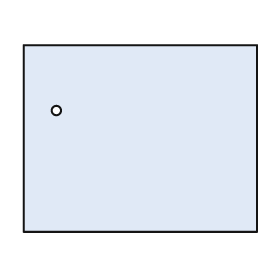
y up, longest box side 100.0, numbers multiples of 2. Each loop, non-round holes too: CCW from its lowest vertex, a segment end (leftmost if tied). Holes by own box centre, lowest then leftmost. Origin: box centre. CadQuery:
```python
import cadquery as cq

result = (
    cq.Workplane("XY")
    .moveTo(-50.0, -40.0)
    .lineTo(50.0, -40.0)
    .lineTo(50.0, 40.0)
    .lineTo(-50.0, 40.0)
    .close()
    .moveTo(-36.0, 12.0)
    .circle(2.0)
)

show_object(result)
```